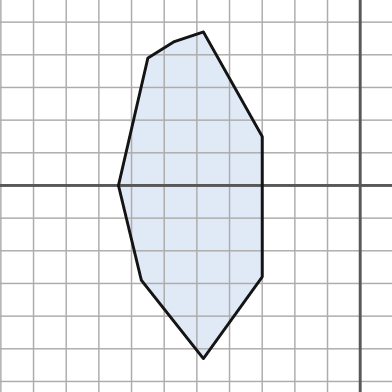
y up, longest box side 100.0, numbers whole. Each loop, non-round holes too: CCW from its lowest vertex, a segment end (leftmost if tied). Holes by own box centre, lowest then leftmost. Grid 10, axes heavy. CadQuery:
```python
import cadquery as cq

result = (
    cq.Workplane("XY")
    .moveTo(-48.0, -53.0)
    .lineTo(-30.0, -28.0)
    .lineTo(-30.0, 15.0)
    .lineTo(-48.0, 47.0)
    .lineTo(-57.0, 44.0)
    .lineTo(-65.0, 39.0)
    .lineTo(-74.0, 0.0)
    .lineTo(-67.0, -29.0)
    .close()
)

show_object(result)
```